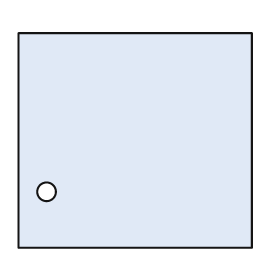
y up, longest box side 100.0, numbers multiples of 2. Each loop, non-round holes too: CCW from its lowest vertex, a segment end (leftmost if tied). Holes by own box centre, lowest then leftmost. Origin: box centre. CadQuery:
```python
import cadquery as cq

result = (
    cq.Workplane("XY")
    .moveTo(-50.0, -46.0)
    .lineTo(50.0, -46.0)
    .lineTo(50.0, 46.0)
    .lineTo(-50.0, 46.0)
    .close()
    .moveTo(-38.0, -22.0)
    .circle(4.0)
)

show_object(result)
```